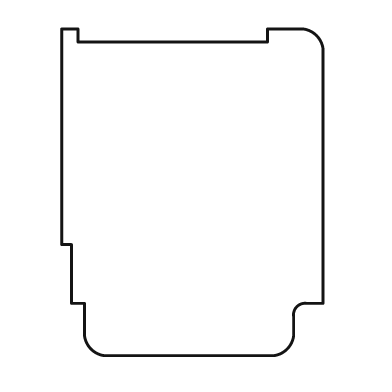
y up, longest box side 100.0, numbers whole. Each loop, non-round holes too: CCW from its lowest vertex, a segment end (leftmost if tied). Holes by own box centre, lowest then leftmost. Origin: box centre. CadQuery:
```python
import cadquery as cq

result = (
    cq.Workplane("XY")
    .moveTo(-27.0, -50.0)
    .lineTo(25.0, -50.0)
    .threePointArc((29.0, -48.0), (31.0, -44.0))
    .lineTo(31.0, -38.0)
    .threePointArc((32.0, -35.0), (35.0, -34.0))
    .lineTo(40.0, -34.0)
    .lineTo(40.0, 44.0)
    .threePointArc((38.0, 48.0), (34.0, 50.0))
    .lineTo(23.0, 50.0)
    .lineTo(23.0, 46.0)
    .lineTo(-35.0, 46.0)
    .lineTo(-35.0, 50.0)
    .lineTo(-40.0, 50.0)
    .lineTo(-40.0, -16.0)
    .lineTo(-37.0, -16.0)
    .lineTo(-37.0, -34.0)
    .lineTo(-33.0, -34.0)
    .lineTo(-33.0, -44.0)
    .threePointArc((-31.0, -48.0), (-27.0, -50.0))
    .close()
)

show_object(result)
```